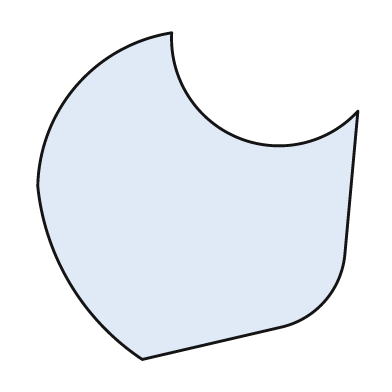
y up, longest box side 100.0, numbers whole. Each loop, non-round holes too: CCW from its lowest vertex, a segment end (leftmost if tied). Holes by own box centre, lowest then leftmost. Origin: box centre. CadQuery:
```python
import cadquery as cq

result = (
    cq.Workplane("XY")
    .moveTo(-17.0, -50.0)
    .lineTo(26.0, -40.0)
    .threePointArc((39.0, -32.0), (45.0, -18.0))
    .lineTo(49.0, 26.0)
    .threePointArc((12.0, 18.0), (-8.0, 50.0))
    .threePointArc((-37.0, 34.0), (-49.0, 3.0))
    .threePointArc((-39.0, -27.0), (-17.0, -50.0))
    .close()
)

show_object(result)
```